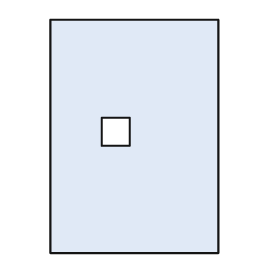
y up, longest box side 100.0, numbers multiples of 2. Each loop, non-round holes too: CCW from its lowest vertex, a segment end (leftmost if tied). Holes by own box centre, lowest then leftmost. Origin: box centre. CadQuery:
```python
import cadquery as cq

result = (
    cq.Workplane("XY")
    .moveTo(-36.0, -50.0)
    .lineTo(36.0, -50.0)
    .lineTo(36.0, 50.0)
    .lineTo(-36.0, 50.0)
    .close()
    .moveTo(-14.0, -4.0)
    .lineTo(-2.0, -4.0)
    .lineTo(-2.0, 8.0)
    .lineTo(-14.0, 8.0)
    .close()
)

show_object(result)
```